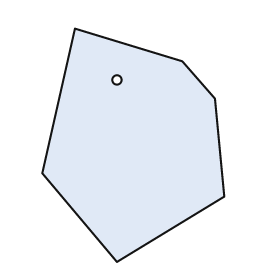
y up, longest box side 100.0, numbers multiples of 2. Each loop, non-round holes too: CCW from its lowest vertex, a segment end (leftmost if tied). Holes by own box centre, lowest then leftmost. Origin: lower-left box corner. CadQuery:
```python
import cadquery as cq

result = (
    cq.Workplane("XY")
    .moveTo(32.0, 0.0)
    .lineTo(78.0, 28.0)
    .lineTo(74.0, 70.0)
    .lineTo(60.0, 86.0)
    .lineTo(14.0, 100.0)
    .lineTo(0.0, 38.0)
    .close()
    .moveTo(32.0, 78.0)
    .circle(2.0)
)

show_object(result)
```